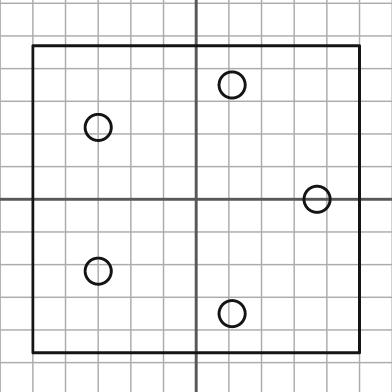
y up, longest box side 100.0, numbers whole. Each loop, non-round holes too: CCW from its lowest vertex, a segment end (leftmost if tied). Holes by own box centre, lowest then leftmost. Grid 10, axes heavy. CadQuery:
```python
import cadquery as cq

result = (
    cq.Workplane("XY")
    .moveTo(-50.0, -47.0)
    .lineTo(50.0, -47.0)
    .lineTo(50.0, 47.0)
    .lineTo(-50.0, 47.0)
    .close()
    .moveTo(11.0, -35.0)
    .circle(4.0)
    .moveTo(-30.0, -22.0)
    .circle(4.0)
    .moveTo(37.0, 0.0)
    .circle(4.0)
    .moveTo(-30.0, 22.0)
    .circle(4.0)
    .moveTo(11.0, 35.0)
    .circle(4.0)
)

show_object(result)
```